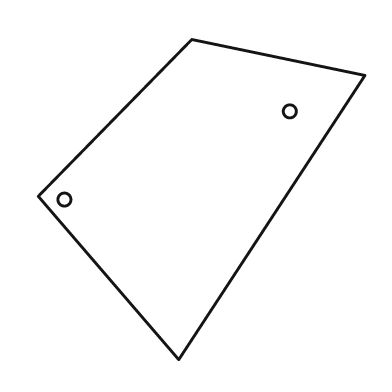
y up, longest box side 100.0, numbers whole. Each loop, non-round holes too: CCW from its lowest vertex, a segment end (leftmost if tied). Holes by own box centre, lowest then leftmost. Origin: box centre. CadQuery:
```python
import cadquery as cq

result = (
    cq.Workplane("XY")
    .moveTo(-7.0, -49.0)
    .lineTo(50.0, 38.0)
    .lineTo(-3.0, 49.0)
    .lineTo(-50.0, 1.0)
    .close()
    .moveTo(-42.0, 0.0)
    .circle(2.0)
    .moveTo(27.0, 27.0)
    .circle(2.0)
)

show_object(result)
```